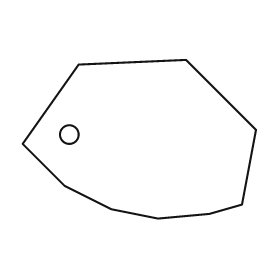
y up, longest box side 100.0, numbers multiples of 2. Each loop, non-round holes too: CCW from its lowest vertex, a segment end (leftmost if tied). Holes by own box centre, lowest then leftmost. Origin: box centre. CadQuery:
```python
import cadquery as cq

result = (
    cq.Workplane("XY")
    .moveTo(8.0, -34.0)
    .lineTo(30.0, -32.0)
    .lineTo(44.0, -28.0)
    .lineTo(50.0, 4.0)
    .lineTo(20.0, 34.0)
    .lineTo(-26.0, 32.0)
    .lineTo(-50.0, -2.0)
    .lineTo(-32.0, -20.0)
    .lineTo(-12.0, -30.0)
    .close()
    .moveTo(-30.0, 2.0)
    .circle(4.0)
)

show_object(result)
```